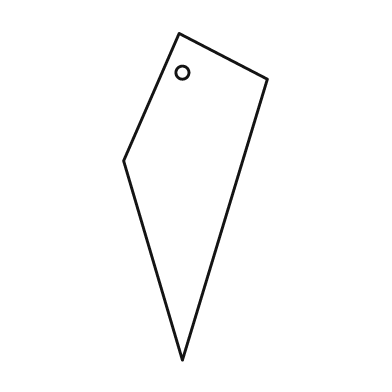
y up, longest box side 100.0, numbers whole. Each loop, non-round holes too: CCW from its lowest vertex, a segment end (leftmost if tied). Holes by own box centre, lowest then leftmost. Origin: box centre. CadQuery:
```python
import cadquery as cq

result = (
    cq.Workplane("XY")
    .moveTo(-4.0, -50.0)
    .lineTo(22.0, 36.0)
    .lineTo(-5.0, 50.0)
    .lineTo(-22.0, 11.0)
    .close()
    .moveTo(-4.0, 38.0)
    .circle(2.0)
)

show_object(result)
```